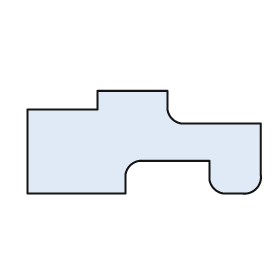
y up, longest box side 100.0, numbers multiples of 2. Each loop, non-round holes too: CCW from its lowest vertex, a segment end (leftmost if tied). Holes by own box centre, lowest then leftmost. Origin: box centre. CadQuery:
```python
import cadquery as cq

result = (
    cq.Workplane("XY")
    .moveTo(-50.0, -22.0)
    .lineTo(-8.0, -22.0)
    .lineTo(-8.0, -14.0)
    .threePointArc((-6.0, -10.0), (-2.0, -8.0))
    .lineTo(28.0, -8.0)
    .lineTo(28.0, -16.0)
    .threePointArc((30.0, -20.0), (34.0, -22.0))
    .lineTo(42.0, -22.0)
    .threePointArc((48.0, -20.0), (50.0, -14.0))
    .lineTo(50.0, 8.0)
    .lineTo(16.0, 8.0)
    .threePointArc((12.0, 10.0), (10.0, 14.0))
    .lineTo(10.0, 22.0)
    .lineTo(-20.0, 22.0)
    .lineTo(-20.0, 14.0)
    .lineTo(-50.0, 14.0)
    .close()
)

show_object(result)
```